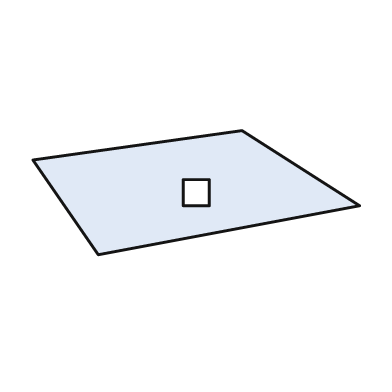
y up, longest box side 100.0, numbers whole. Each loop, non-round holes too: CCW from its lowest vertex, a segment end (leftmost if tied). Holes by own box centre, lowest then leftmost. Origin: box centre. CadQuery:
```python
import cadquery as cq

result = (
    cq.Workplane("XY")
    .moveTo(-30.0, -19.0)
    .lineTo(50.0, -4.0)
    .lineTo(14.0, 19.0)
    .lineTo(-50.0, 10.0)
    .close()
    .moveTo(-4.0, -4.0)
    .lineTo(4.0, -4.0)
    .lineTo(4.0, 4.0)
    .lineTo(-4.0, 4.0)
    .close()
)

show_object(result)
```